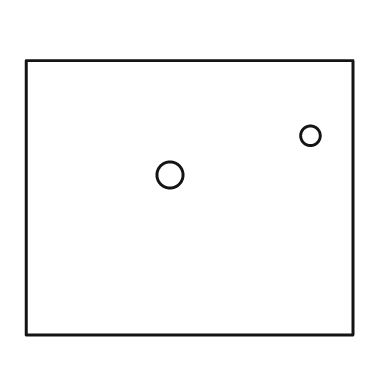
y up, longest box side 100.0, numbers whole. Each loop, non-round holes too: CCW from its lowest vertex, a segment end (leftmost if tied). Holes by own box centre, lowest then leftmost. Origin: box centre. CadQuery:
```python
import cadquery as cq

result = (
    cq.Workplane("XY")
    .moveTo(-50.0, -42.0)
    .lineTo(50.0, -42.0)
    .lineTo(50.0, 42.0)
    .lineTo(-50.0, 42.0)
    .close()
    .moveTo(-6.0, 7.0)
    .circle(4.0)
    .moveTo(37.0, 19.0)
    .circle(3.0)
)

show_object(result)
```